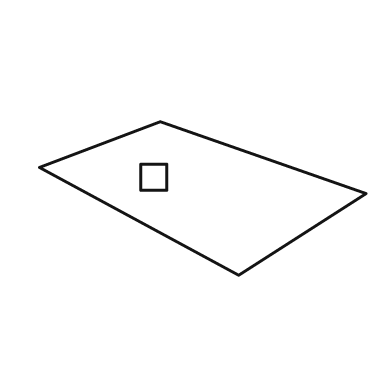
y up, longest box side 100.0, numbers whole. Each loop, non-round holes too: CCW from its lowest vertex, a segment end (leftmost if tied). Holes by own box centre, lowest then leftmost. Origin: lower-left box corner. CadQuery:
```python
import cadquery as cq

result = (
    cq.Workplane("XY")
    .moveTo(61.0, 0.0)
    .lineTo(100.0, 25.0)
    .lineTo(37.0, 47.0)
    .lineTo(0.0, 33.0)
    .close()
    .moveTo(31.0, 26.0)
    .lineTo(39.0, 26.0)
    .lineTo(39.0, 34.0)
    .lineTo(31.0, 34.0)
    .close()
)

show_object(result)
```